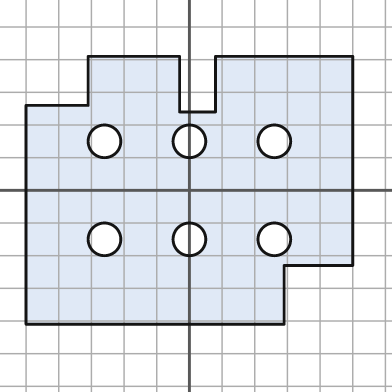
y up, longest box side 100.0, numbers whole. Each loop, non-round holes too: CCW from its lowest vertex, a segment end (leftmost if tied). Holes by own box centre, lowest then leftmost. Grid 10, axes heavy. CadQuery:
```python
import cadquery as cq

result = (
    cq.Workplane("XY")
    .moveTo(-50.0, -41.0)
    .lineTo(29.0, -41.0)
    .lineTo(29.0, -23.0)
    .lineTo(50.0, -23.0)
    .lineTo(50.0, 41.0)
    .lineTo(8.0, 41.0)
    .lineTo(8.0, 24.0)
    .lineTo(-3.0, 24.0)
    .lineTo(-3.0, 41.0)
    .lineTo(-31.0, 41.0)
    .lineTo(-31.0, 26.0)
    .lineTo(-50.0, 26.0)
    .close()
    .moveTo(-26.0, -15.0)
    .circle(5.0)
    .moveTo(0.0, -15.0)
    .circle(5.0)
    .moveTo(26.0, -15.0)
    .circle(5.0)
    .moveTo(-26.0, 15.0)
    .circle(5.0)
    .moveTo(0.0, 15.0)
    .circle(5.0)
    .moveTo(26.0, 15.0)
    .circle(5.0)
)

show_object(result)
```